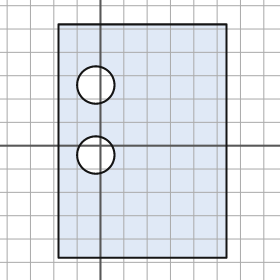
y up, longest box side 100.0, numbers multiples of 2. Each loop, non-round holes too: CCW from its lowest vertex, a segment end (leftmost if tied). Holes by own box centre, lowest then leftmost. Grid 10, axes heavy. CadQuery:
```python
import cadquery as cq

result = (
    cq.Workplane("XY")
    .moveTo(-18.0, -48.0)
    .lineTo(54.0, -48.0)
    .lineTo(54.0, 52.0)
    .lineTo(-18.0, 52.0)
    .close()
    .moveTo(-2.0, -4.0)
    .circle(8.0)
    .moveTo(-2.0, 26.0)
    .circle(8.0)
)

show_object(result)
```